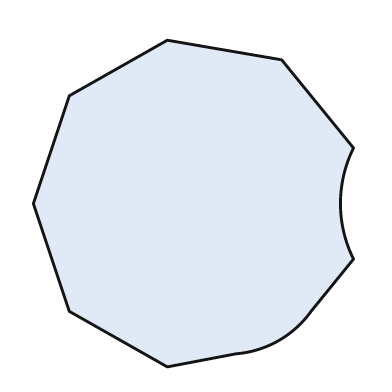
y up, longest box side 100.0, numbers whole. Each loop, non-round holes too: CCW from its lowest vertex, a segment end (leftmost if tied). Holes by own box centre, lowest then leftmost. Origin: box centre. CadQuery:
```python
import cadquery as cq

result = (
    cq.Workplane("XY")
    .moveTo(-8.0, -50.0)
    .lineTo(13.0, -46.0)
    .threePointArc((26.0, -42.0), (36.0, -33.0))
    .lineTo(49.0, -17.0)
    .threePointArc((45.0, 0.0), (49.0, 17.0))
    .lineTo(27.0, 44.0)
    .lineTo(-8.0, 50.0)
    .lineTo(-38.0, 33.0)
    .lineTo(-49.0, 0.0)
    .lineTo(-38.0, -33.0)
    .close()
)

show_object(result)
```